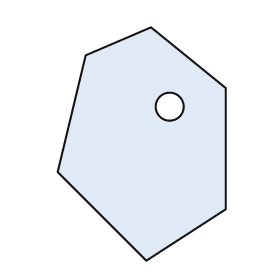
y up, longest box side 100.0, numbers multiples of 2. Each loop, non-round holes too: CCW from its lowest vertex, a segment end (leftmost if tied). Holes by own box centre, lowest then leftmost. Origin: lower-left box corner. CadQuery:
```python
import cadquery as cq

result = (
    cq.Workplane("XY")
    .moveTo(38.0, 0.0)
    .lineTo(72.0, 22.0)
    .lineTo(72.0, 74.0)
    .lineTo(40.0, 100.0)
    .lineTo(12.0, 88.0)
    .lineTo(0.0, 38.0)
    .close()
    .moveTo(48.0, 66.0)
    .circle(6.0)
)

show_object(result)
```